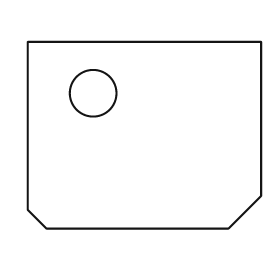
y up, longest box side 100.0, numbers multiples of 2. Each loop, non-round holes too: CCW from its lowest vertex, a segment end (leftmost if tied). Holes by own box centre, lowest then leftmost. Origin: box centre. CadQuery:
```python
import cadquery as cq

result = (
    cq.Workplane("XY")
    .moveTo(-42.0, -40.0)
    .lineTo(36.0, -40.0)
    .lineTo(50.0, -26.0)
    .lineTo(50.0, 40.0)
    .lineTo(-50.0, 40.0)
    .lineTo(-50.0, -32.0)
    .close()
    .moveTo(-22.0, 18.0)
    .circle(10.0)
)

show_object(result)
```